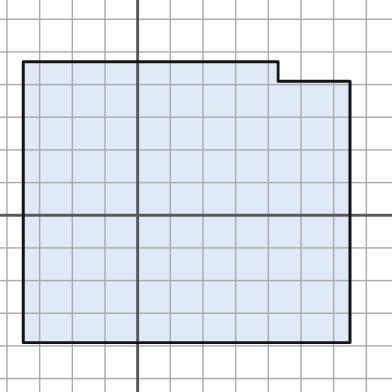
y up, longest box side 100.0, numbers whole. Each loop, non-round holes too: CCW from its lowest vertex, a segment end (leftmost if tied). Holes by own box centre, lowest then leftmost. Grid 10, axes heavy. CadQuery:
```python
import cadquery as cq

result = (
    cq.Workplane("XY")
    .moveTo(-35.0, -39.0)
    .lineTo(65.0, -39.0)
    .lineTo(65.0, 41.0)
    .lineTo(43.0, 41.0)
    .lineTo(43.0, 47.0)
    .lineTo(-35.0, 47.0)
    .close()
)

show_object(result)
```